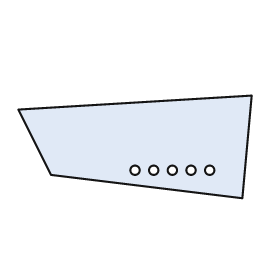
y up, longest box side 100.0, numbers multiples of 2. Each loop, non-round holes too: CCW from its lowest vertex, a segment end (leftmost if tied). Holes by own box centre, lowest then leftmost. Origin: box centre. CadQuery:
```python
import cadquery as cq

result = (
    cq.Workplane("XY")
    .moveTo(46.0, -22.0)
    .lineTo(50.0, 22.0)
    .lineTo(-50.0, 16.0)
    .lineTo(-36.0, -12.0)
    .close()
    .moveTo(0.0, -10.0)
    .circle(2.0)
    .moveTo(8.0, -10.0)
    .circle(2.0)
    .moveTo(16.0, -10.0)
    .circle(2.0)
    .moveTo(24.0, -10.0)
    .circle(2.0)
    .moveTo(32.0, -10.0)
    .circle(2.0)
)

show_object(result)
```